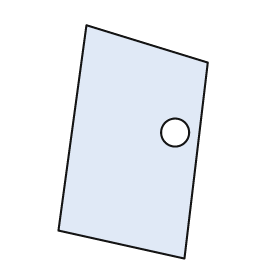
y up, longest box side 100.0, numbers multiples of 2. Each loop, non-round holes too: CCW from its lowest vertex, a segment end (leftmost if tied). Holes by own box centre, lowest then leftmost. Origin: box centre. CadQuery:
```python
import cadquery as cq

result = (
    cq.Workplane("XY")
    .moveTo(22.0, -50.0)
    .lineTo(32.0, 34.0)
    .lineTo(-20.0, 50.0)
    .lineTo(-32.0, -38.0)
    .close()
    .moveTo(18.0, 4.0)
    .circle(6.0)
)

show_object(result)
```